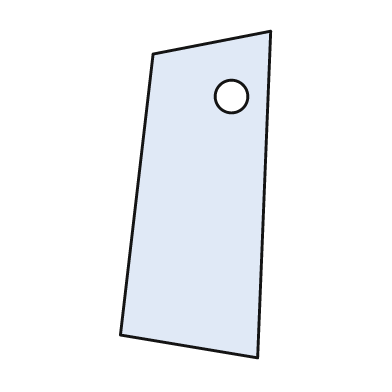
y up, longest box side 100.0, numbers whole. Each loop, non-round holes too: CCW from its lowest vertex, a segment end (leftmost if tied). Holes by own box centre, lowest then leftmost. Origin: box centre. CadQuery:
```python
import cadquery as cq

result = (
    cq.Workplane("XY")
    .moveTo(19.0, -50.0)
    .lineTo(23.0, 50.0)
    .lineTo(-13.0, 43.0)
    .lineTo(-23.0, -43.0)
    .close()
    .moveTo(11.0, 30.0)
    .circle(5.0)
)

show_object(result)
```